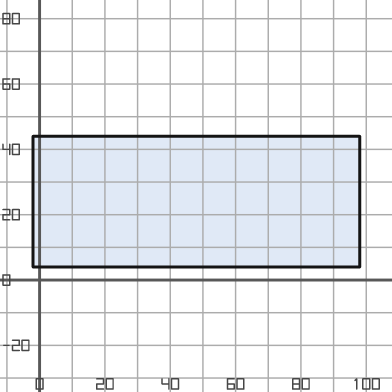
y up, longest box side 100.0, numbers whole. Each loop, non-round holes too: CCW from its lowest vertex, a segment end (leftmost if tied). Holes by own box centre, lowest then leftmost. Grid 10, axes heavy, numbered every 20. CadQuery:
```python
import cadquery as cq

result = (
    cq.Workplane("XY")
    .moveTo(-2.0, 4.0)
    .lineTo(98.0, 4.0)
    .lineTo(98.0, 44.0)
    .lineTo(-2.0, 44.0)
    .close()
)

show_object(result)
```